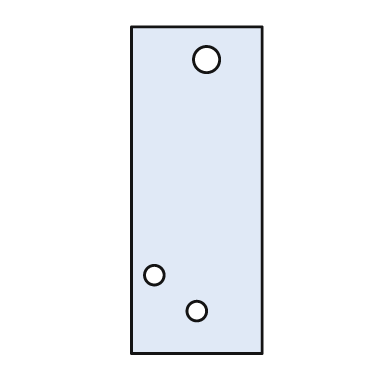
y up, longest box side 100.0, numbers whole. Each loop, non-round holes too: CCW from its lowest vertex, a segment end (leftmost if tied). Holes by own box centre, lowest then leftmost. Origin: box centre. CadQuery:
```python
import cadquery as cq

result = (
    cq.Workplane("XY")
    .moveTo(-20.0, -50.0)
    .lineTo(20.0, -50.0)
    .lineTo(20.0, 50.0)
    .lineTo(-20.0, 50.0)
    .close()
    .moveTo(0.0, -37.0)
    .circle(3.0)
    .moveTo(-13.0, -26.0)
    .circle(3.0)
    .moveTo(3.0, 40.0)
    .circle(4.0)
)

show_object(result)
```